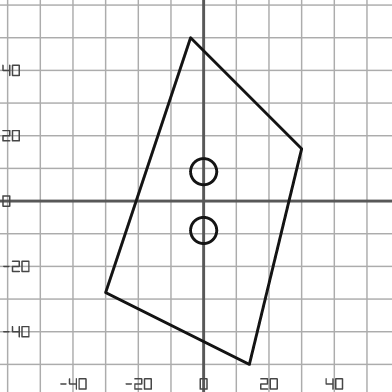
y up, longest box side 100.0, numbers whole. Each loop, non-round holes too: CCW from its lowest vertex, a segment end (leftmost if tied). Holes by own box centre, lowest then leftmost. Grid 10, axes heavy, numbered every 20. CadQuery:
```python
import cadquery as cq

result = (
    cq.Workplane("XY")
    .moveTo(14.0, -50.0)
    .lineTo(30.0, 16.0)
    .lineTo(-4.0, 50.0)
    .lineTo(-30.0, -28.0)
    .close()
    .moveTo(0.0, -9.0)
    .circle(4.0)
    .moveTo(0.0, 9.0)
    .circle(4.0)
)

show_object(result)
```